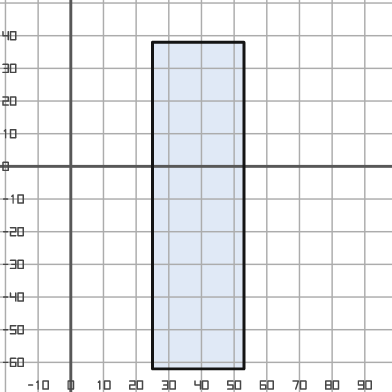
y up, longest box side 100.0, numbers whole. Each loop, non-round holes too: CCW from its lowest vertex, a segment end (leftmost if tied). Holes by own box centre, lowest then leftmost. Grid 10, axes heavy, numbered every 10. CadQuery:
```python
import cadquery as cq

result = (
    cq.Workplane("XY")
    .moveTo(25.0, -62.0)
    .lineTo(53.0, -62.0)
    .lineTo(53.0, 38.0)
    .lineTo(25.0, 38.0)
    .close()
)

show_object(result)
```